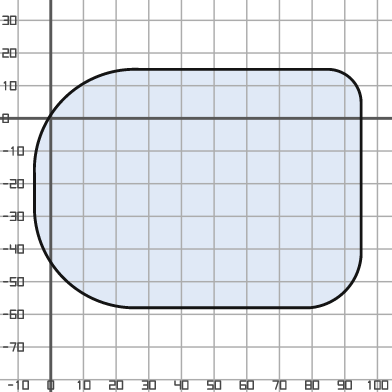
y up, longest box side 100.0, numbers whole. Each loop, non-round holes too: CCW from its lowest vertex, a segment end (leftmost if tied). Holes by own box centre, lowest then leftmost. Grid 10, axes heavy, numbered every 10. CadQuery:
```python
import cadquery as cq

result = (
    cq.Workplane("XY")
    .moveTo(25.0, -58.0)
    .lineTo(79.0, -58.0)
    .threePointArc((90.0, -53.0), (95.0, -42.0))
    .lineTo(95.0, 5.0)
    .threePointArc((92.0, 12.0), (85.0, 15.0))
    .lineTo(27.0, 15.0)
    .threePointArc((4.0, 6.0), (-5.0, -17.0))
    .lineTo(-5.0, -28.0)
    .threePointArc((4.0, -49.0), (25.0, -58.0))
    .close()
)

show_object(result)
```